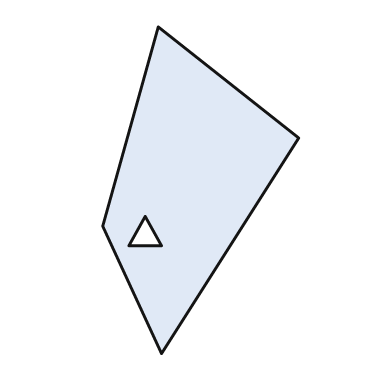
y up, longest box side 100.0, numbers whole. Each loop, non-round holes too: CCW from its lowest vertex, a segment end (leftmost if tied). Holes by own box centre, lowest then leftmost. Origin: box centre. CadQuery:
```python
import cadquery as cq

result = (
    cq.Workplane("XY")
    .moveTo(-12.0, -50.0)
    .lineTo(30.0, 16.0)
    .lineTo(-13.0, 50.0)
    .lineTo(-30.0, -11.0)
    .close()
    .moveTo(-22.0, -17.0)
    .lineTo(-12.0, -17.0)
    .lineTo(-17.0, -8.0)
    .close()
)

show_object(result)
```